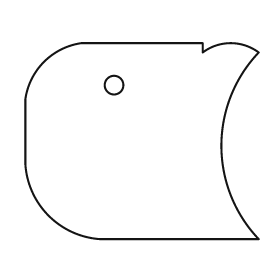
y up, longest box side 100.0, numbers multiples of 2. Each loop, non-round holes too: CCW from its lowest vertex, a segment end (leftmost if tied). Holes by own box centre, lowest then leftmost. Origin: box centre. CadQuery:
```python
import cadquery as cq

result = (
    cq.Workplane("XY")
    .moveTo(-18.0, -42.0)
    .lineTo(50.0, -42.0)
    .threePointArc((34.0, -2.0), (50.0, 38.0))
    .threePointArc((38.0, 42.0), (26.0, 38.0))
    .lineTo(26.0, 42.0)
    .lineTo(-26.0, 42.0)
    .threePointArc((-42.0, 34.0), (-50.0, 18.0))
    .lineTo(-50.0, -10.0)
    .threePointArc((-40.0, -32.0), (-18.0, -42.0))
    .close()
    .moveTo(-12.0, 24.0)
    .circle(4.0)
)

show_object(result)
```